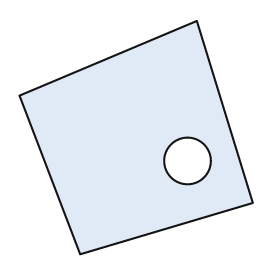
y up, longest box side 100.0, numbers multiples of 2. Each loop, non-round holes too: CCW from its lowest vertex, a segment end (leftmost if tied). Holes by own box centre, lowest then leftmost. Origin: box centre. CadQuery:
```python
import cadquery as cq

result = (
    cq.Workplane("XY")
    .moveTo(-24.0, -50.0)
    .lineTo(50.0, -28.0)
    .lineTo(26.0, 50.0)
    .lineTo(-50.0, 18.0)
    .close()
    .moveTo(22.0, -10.0)
    .circle(10.0)
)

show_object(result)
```